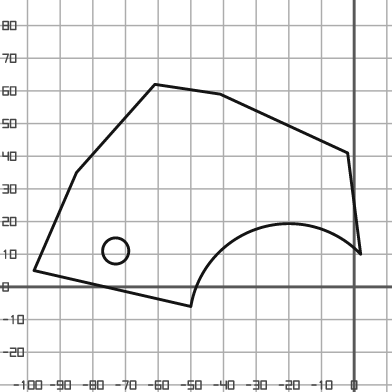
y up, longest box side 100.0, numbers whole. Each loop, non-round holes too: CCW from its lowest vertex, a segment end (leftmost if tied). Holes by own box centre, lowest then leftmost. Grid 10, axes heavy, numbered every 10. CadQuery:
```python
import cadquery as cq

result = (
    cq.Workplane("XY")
    .moveTo(-50.0, -6.0)
    .threePointArc((-29.0, 18.0), (2.0, 10.0))
    .lineTo(-2.0, 41.0)
    .lineTo(-41.0, 59.0)
    .lineTo(-61.0, 62.0)
    .lineTo(-85.0, 35.0)
    .lineTo(-98.0, 5.0)
    .close()
    .moveTo(-73.0, 11.0)
    .circle(4.0)
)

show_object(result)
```